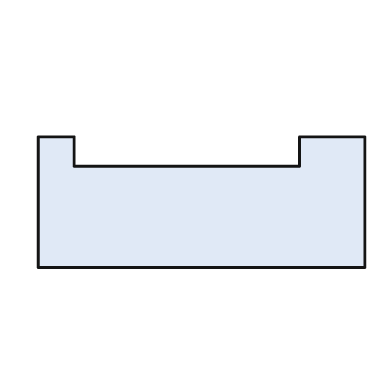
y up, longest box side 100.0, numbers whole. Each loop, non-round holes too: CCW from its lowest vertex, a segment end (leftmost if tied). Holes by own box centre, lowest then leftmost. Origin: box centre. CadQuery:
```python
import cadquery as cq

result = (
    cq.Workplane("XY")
    .moveTo(-50.0, -20.0)
    .lineTo(50.0, -20.0)
    .lineTo(50.0, 20.0)
    .lineTo(30.0, 20.0)
    .lineTo(30.0, 11.0)
    .lineTo(-39.0, 11.0)
    .lineTo(-39.0, 20.0)
    .lineTo(-50.0, 20.0)
    .close()
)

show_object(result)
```